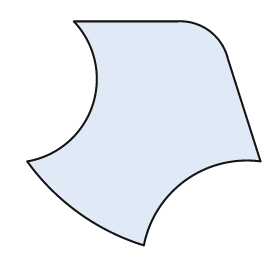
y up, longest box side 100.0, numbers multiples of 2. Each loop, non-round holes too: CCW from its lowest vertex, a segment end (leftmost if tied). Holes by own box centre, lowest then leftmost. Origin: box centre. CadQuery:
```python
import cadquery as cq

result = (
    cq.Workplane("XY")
    .moveTo(0.0, -48.0)
    .threePointArc((18.0, -20.0), (50.0, -12.0))
    .lineTo(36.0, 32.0)
    .threePointArc((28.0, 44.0), (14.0, 48.0))
    .lineTo(-30.0, 48.0)
    .threePointArc((-22.0, 12.0), (-50.0, -12.0))
    .threePointArc((-28.0, -34.0), (0.0, -48.0))
    .close()
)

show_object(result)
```